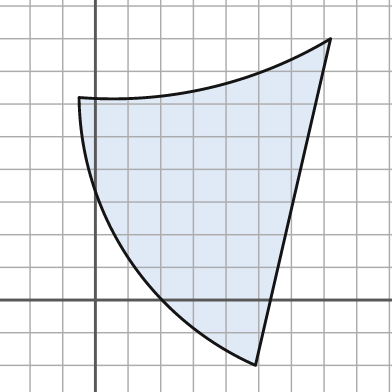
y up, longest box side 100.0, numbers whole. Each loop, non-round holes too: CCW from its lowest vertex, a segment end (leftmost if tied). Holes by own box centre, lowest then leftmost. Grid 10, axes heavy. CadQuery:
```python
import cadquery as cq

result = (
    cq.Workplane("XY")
    .moveTo(49.0, -20.0)
    .lineTo(72.0, 80.0)
    .threePointArc((35.0, 65.0), (-5.0, 62.0))
    .threePointArc((10.0, 13.0), (49.0, -20.0))
    .close()
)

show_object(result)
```